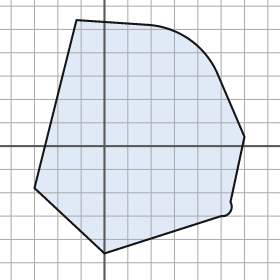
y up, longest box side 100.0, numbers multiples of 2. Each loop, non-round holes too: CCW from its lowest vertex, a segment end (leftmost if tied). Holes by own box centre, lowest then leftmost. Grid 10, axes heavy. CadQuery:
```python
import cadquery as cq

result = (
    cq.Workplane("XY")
    .moveTo(0.0, -46.0)
    .lineTo(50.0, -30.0)
    .threePointArc((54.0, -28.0), (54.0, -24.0))
    .lineTo(60.0, 4.0)
    .lineTo(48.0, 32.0)
    .threePointArc((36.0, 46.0), (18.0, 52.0))
    .lineTo(-12.0, 54.0)
    .lineTo(-30.0, -18.0)
    .close()
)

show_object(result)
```